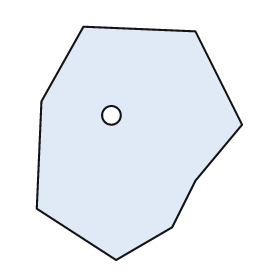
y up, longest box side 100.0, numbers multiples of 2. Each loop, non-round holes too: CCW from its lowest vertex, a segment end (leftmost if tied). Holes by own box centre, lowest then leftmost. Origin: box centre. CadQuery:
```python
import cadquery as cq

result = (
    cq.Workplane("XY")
    .moveTo(-10.0, -50.0)
    .lineTo(14.0, -36.0)
    .lineTo(24.0, -16.0)
    .lineTo(44.0, 8.0)
    .lineTo(24.0, 48.0)
    .lineTo(-24.0, 50.0)
    .lineTo(-42.0, 18.0)
    .lineTo(-44.0, -28.0)
    .close()
    .moveTo(-12.0, 12.0)
    .circle(4.0)
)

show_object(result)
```